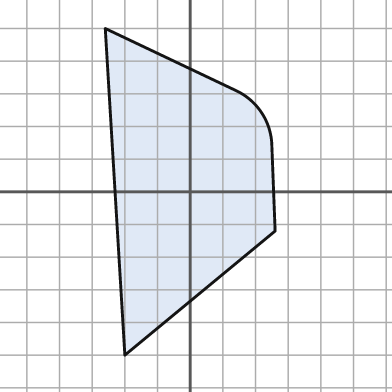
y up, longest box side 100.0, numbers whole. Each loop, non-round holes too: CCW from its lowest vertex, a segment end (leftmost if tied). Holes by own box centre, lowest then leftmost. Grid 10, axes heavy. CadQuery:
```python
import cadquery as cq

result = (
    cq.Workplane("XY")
    .moveTo(-20.0, -50.0)
    .lineTo(26.0, -12.0)
    .lineTo(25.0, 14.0)
    .threePointArc((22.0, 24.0), (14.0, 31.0))
    .lineTo(-26.0, 50.0)
    .close()
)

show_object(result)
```